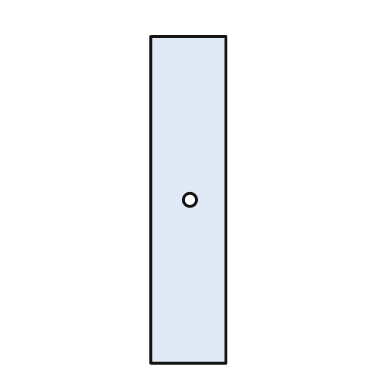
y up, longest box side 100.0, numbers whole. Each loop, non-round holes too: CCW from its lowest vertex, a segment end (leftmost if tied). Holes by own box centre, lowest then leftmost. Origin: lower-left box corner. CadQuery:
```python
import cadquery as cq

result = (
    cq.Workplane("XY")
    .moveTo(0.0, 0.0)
    .lineTo(23.0, 0.0)
    .lineTo(23.0, 100.0)
    .lineTo(0.0, 100.0)
    .close()
    .moveTo(12.0, 50.0)
    .circle(2.0)
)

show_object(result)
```